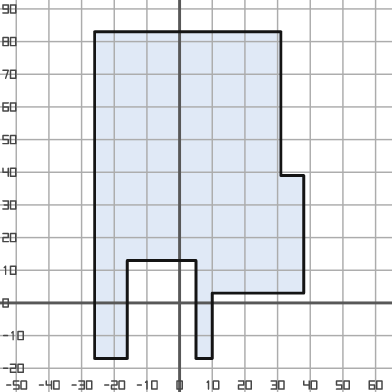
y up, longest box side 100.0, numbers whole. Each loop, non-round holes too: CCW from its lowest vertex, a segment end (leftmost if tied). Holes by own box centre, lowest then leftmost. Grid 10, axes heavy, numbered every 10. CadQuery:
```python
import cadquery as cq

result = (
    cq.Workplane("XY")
    .moveTo(-26.0, -17.0)
    .lineTo(-16.0, -17.0)
    .lineTo(-16.0, 13.0)
    .lineTo(5.0, 13.0)
    .lineTo(5.0, -17.0)
    .lineTo(10.0, -17.0)
    .lineTo(10.0, 3.0)
    .lineTo(38.0, 3.0)
    .lineTo(38.0, 39.0)
    .lineTo(31.0, 39.0)
    .lineTo(31.0, 83.0)
    .lineTo(-26.0, 83.0)
    .close()
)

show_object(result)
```